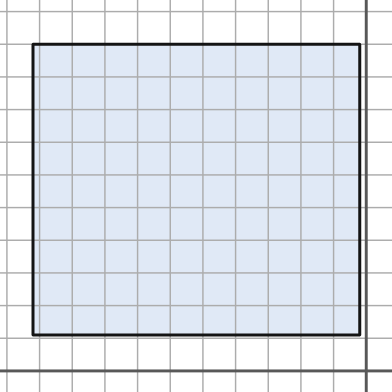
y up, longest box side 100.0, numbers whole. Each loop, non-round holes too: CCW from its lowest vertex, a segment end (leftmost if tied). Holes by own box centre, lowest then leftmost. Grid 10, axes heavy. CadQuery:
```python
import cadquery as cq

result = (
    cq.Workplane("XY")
    .moveTo(-102.0, 11.0)
    .lineTo(-2.0, 11.0)
    .lineTo(-2.0, 100.0)
    .lineTo(-102.0, 100.0)
    .close()
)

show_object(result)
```